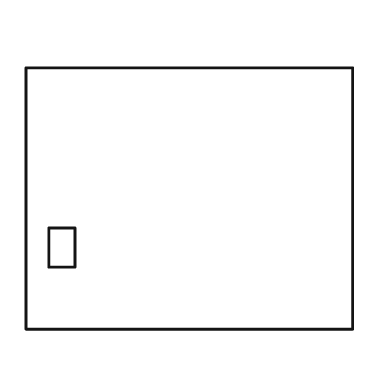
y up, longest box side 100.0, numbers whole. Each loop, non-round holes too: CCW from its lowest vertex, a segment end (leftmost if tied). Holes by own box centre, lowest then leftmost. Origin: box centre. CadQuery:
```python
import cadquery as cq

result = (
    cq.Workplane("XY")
    .moveTo(-50.0, -40.0)
    .lineTo(50.0, -40.0)
    .lineTo(50.0, 40.0)
    .lineTo(-50.0, 40.0)
    .close()
    .moveTo(-43.0, -21.0)
    .lineTo(-35.0, -21.0)
    .lineTo(-35.0, -9.0)
    .lineTo(-43.0, -9.0)
    .close()
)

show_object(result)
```